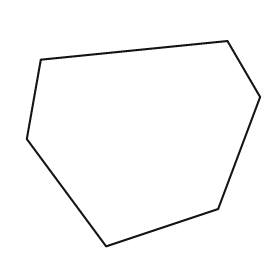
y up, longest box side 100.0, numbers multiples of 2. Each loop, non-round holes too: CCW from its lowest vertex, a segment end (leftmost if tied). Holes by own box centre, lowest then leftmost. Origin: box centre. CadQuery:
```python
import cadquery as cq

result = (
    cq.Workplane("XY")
    .moveTo(-16.0, -44.0)
    .lineTo(32.0, -28.0)
    .lineTo(50.0, 20.0)
    .lineTo(36.0, 44.0)
    .lineTo(-44.0, 36.0)
    .lineTo(-50.0, 2.0)
    .close()
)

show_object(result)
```